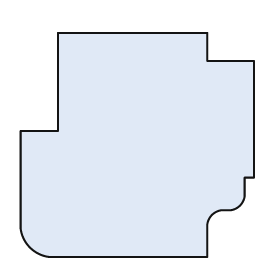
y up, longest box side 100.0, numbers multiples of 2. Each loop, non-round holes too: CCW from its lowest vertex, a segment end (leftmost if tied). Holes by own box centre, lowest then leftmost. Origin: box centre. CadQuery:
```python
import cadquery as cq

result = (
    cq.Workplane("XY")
    .moveTo(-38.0, -48.0)
    .lineTo(30.0, -48.0)
    .lineTo(30.0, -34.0)
    .threePointArc((32.0, -30.0), (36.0, -28.0))
    .lineTo(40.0, -28.0)
    .threePointArc((44.0, -26.0), (46.0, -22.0))
    .lineTo(46.0, -14.0)
    .lineTo(50.0, -14.0)
    .lineTo(50.0, 36.0)
    .lineTo(30.0, 36.0)
    .lineTo(30.0, 48.0)
    .lineTo(-34.0, 48.0)
    .lineTo(-34.0, 6.0)
    .lineTo(-50.0, 6.0)
    .lineTo(-50.0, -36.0)
    .threePointArc((-46.0, -44.0), (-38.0, -48.0))
    .close()
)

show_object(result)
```